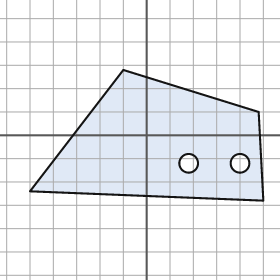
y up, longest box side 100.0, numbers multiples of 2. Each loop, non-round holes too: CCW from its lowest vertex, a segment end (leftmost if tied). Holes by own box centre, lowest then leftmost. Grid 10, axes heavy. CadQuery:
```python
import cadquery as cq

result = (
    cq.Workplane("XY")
    .moveTo(50.0, -28.0)
    .lineTo(48.0, 10.0)
    .lineTo(-10.0, 28.0)
    .lineTo(-50.0, -24.0)
    .close()
    .moveTo(18.0, -12.0)
    .circle(4.0)
    .moveTo(40.0, -12.0)
    .circle(4.0)
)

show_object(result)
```